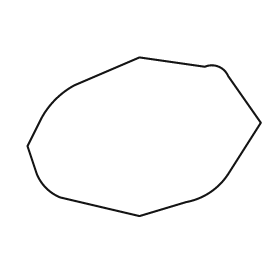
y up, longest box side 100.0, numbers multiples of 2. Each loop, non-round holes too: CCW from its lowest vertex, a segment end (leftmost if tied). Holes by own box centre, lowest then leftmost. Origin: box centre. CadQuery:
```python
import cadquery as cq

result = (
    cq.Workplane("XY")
    .moveTo(-2.0, -34.0)
    .lineTo(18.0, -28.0)
    .threePointArc((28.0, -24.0), (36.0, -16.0))
    .lineTo(50.0, 6.0)
    .lineTo(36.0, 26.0)
    .threePointArc((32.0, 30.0), (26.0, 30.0))
    .lineTo(-2.0, 34.0)
    .lineTo(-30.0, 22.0)
    .threePointArc((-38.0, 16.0), (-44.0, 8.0))
    .lineTo(-50.0, -4.0)
    .lineTo(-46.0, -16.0)
    .threePointArc((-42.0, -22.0), (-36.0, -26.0))
    .close()
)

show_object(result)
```